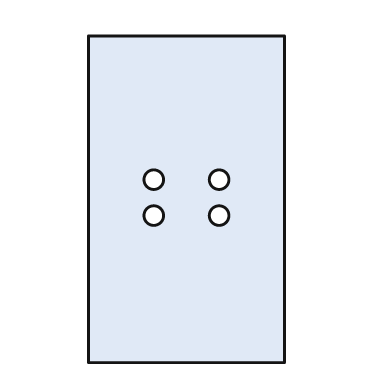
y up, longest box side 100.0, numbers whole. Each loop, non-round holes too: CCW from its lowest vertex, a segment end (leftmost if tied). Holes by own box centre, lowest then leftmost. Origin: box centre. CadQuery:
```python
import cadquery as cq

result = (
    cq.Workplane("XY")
    .moveTo(-30.0, -50.0)
    .lineTo(30.0, -50.0)
    .lineTo(30.0, 50.0)
    .lineTo(-30.0, 50.0)
    .close()
    .moveTo(-10.0, -5.0)
    .circle(3.0)
    .moveTo(10.0, -5.0)
    .circle(3.0)
    .moveTo(-10.0, 6.0)
    .circle(3.0)
    .moveTo(10.0, 6.0)
    .circle(3.0)
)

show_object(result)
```